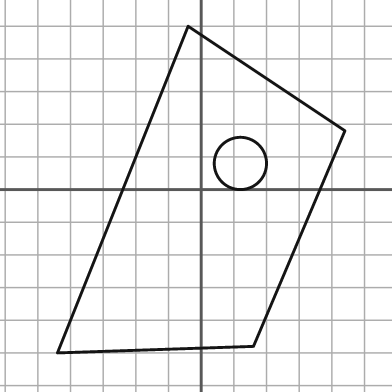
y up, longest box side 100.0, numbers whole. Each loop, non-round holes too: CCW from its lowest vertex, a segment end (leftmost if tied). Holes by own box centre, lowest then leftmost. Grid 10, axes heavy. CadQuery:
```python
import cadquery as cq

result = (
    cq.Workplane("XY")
    .moveTo(-44.0, -50.0)
    .lineTo(16.0, -48.0)
    .lineTo(44.0, 18.0)
    .lineTo(-4.0, 50.0)
    .close()
    .moveTo(12.0, 8.0)
    .circle(8.0)
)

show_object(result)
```